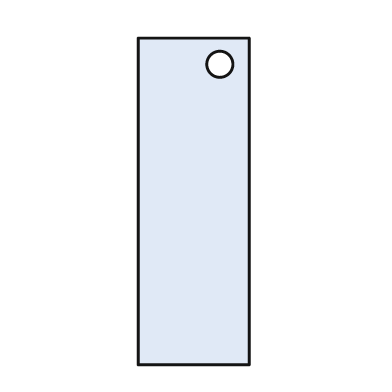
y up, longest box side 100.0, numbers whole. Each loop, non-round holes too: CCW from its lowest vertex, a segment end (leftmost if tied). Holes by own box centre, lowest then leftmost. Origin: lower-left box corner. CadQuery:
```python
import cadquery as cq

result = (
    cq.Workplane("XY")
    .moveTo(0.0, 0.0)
    .lineTo(34.0, 0.0)
    .lineTo(34.0, 100.0)
    .lineTo(0.0, 100.0)
    .close()
    .moveTo(25.0, 92.0)
    .circle(4.0)
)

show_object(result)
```